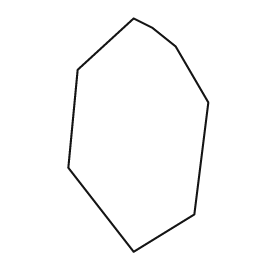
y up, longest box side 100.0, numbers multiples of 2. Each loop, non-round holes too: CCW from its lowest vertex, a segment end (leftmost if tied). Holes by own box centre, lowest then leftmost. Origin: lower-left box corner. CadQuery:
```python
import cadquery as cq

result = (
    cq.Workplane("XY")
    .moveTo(28.0, 0.0)
    .lineTo(54.0, 16.0)
    .lineTo(60.0, 64.0)
    .lineTo(46.0, 88.0)
    .lineTo(36.0, 96.0)
    .lineTo(28.0, 100.0)
    .lineTo(4.0, 78.0)
    .lineTo(0.0, 36.0)
    .close()
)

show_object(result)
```